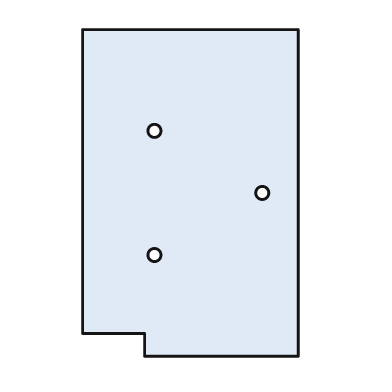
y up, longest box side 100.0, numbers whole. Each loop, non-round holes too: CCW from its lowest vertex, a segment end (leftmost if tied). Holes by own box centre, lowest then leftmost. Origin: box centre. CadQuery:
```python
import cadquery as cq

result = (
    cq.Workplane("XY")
    .moveTo(-14.0, -50.0)
    .lineTo(33.0, -50.0)
    .lineTo(33.0, 50.0)
    .lineTo(-33.0, 50.0)
    .lineTo(-33.0, -43.0)
    .lineTo(-14.0, -43.0)
    .close()
    .moveTo(-11.0, -19.0)
    .circle(2.0)
    .moveTo(22.0, 0.0)
    .circle(2.0)
    .moveTo(-11.0, 19.0)
    .circle(2.0)
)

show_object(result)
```